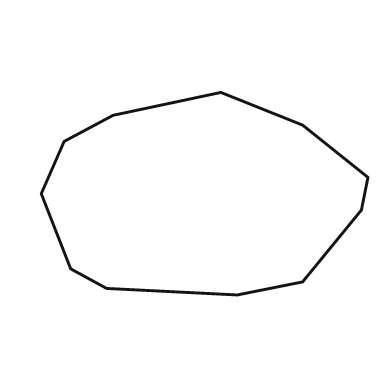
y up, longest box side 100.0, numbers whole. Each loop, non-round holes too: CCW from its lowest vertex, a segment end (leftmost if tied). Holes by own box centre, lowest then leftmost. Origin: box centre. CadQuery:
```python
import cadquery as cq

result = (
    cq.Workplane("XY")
    .moveTo(10.0, -31.0)
    .lineTo(30.0, -27.0)
    .lineTo(48.0, -5.0)
    .lineTo(50.0, 5.0)
    .lineTo(30.0, 21.0)
    .lineTo(5.0, 31.0)
    .lineTo(-28.0, 24.0)
    .lineTo(-43.0, 16.0)
    .lineTo(-50.0, 0.0)
    .lineTo(-41.0, -23.0)
    .lineTo(-30.0, -29.0)
    .close()
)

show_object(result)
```